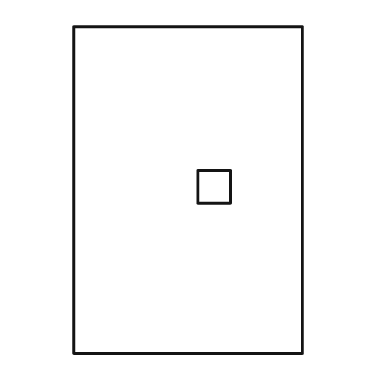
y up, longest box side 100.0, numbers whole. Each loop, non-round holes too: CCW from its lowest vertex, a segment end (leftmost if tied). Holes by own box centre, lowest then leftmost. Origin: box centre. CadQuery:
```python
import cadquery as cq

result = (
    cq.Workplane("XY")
    .moveTo(-35.0, -50.0)
    .lineTo(35.0, -50.0)
    .lineTo(35.0, 50.0)
    .lineTo(-35.0, 50.0)
    .close()
    .moveTo(3.0, -4.0)
    .lineTo(13.0, -4.0)
    .lineTo(13.0, 6.0)
    .lineTo(3.0, 6.0)
    .close()
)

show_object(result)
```